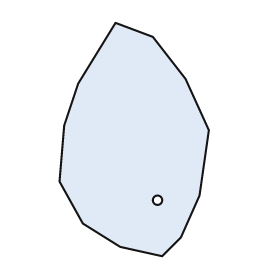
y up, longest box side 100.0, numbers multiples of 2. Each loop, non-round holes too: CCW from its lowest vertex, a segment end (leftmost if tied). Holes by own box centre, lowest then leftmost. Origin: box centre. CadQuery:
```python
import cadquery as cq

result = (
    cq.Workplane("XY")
    .moveTo(12.0, -50.0)
    .lineTo(20.0, -42.0)
    .lineTo(28.0, -24.0)
    .lineTo(32.0, 4.0)
    .lineTo(22.0, 26.0)
    .lineTo(8.0, 44.0)
    .lineTo(-8.0, 50.0)
    .lineTo(-24.0, 24.0)
    .lineTo(-30.0, 6.0)
    .lineTo(-32.0, -18.0)
    .lineTo(-22.0, -36.0)
    .lineTo(-6.0, -46.0)
    .close()
    .moveTo(10.0, -26.0)
    .circle(2.0)
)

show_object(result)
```